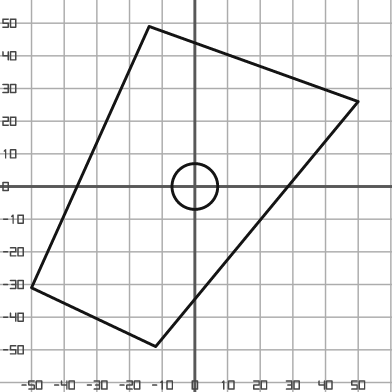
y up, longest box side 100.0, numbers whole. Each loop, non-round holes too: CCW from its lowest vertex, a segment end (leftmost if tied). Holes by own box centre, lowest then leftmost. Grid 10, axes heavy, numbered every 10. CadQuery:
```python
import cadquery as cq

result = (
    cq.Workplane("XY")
    .moveTo(-12.0, -49.0)
    .lineTo(50.0, 26.0)
    .lineTo(-14.0, 49.0)
    .lineTo(-50.0, -31.0)
    .close()
    .moveTo(0.0, 0.0)
    .circle(7.0)
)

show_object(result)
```